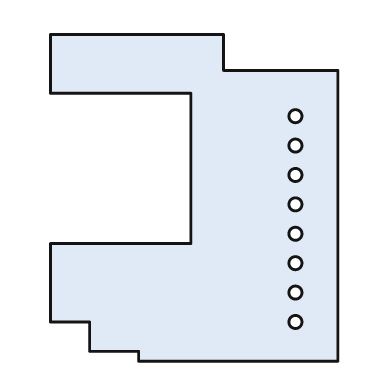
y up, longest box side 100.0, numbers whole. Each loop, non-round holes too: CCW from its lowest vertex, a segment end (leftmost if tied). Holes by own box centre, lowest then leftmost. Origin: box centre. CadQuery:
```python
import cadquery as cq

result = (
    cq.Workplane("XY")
    .moveTo(-17.0, -50.0)
    .lineTo(44.0, -50.0)
    .lineTo(44.0, 39.0)
    .lineTo(9.0, 39.0)
    .lineTo(9.0, 50.0)
    .lineTo(-44.0, 50.0)
    .lineTo(-44.0, 32.0)
    .lineTo(-1.0, 32.0)
    .lineTo(-1.0, -14.0)
    .lineTo(-44.0, -14.0)
    .lineTo(-44.0, -38.0)
    .lineTo(-32.0, -38.0)
    .lineTo(-32.0, -47.0)
    .lineTo(-17.0, -47.0)
    .close()
    .moveTo(31.0, -38.0)
    .circle(2.0)
    .moveTo(31.0, -29.0)
    .circle(2.0)
    .moveTo(31.0, -20.0)
    .circle(2.0)
    .moveTo(31.0, -11.0)
    .circle(2.0)
    .moveTo(31.0, -2.0)
    .circle(2.0)
    .moveTo(31.0, 7.0)
    .circle(2.0)
    .moveTo(31.0, 16.0)
    .circle(2.0)
    .moveTo(31.0, 25.0)
    .circle(2.0)
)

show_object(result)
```